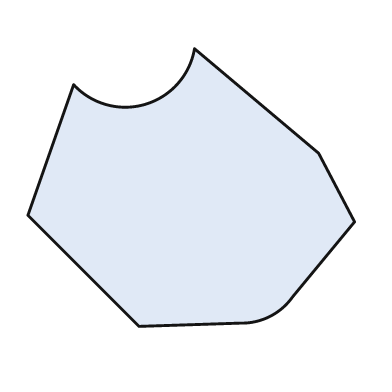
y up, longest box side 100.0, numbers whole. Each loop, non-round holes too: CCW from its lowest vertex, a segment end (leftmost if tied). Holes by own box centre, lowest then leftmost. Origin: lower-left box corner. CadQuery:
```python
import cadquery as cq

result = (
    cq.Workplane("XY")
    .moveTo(34.0, 0.0)
    .lineTo(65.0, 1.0)
    .threePointArc((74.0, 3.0), (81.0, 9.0))
    .lineTo(100.0, 32.0)
    .lineTo(89.0, 53.0)
    .lineTo(51.0, 85.0)
    .threePointArc((36.0, 68.0), (14.0, 74.0))
    .lineTo(0.0, 34.0)
    .close()
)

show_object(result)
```